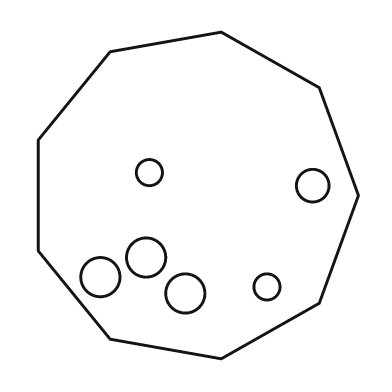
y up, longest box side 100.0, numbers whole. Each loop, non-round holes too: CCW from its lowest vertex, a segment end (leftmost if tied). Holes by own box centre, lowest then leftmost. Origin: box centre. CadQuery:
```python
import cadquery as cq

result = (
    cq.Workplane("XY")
    .moveTo(7.0, -50.0)
    .lineTo(37.0, -33.0)
    .lineTo(49.0, 0.0)
    .lineTo(37.0, 33.0)
    .lineTo(7.0, 50.0)
    .lineTo(-27.0, 44.0)
    .lineTo(-49.0, 17.0)
    .lineTo(-49.0, -17.0)
    .lineTo(-27.0, -44.0)
    .close()
    .moveTo(-4.0, -30.0)
    .circle(6.0)
    .moveTo(21.0, -28.0)
    .circle(4.0)
    .moveTo(-30.0, -25.0)
    .circle(6.0)
    .moveTo(-16.0, -19.0)
    .circle(6.0)
    .moveTo(35.0, 3.0)
    .circle(5.0)
    .moveTo(-15.0, 7.0)
    .circle(4.0)
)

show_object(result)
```